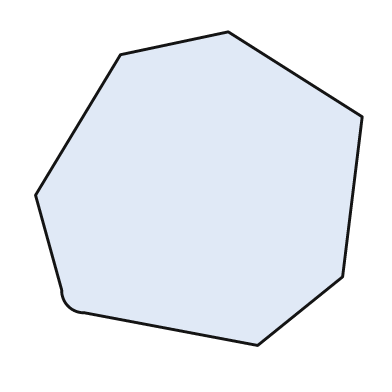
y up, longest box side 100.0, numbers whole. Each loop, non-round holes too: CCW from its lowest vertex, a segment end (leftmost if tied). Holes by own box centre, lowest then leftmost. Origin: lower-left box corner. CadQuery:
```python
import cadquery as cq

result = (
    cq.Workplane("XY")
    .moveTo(68.0, 0.0)
    .lineTo(94.0, 21.0)
    .lineTo(100.0, 70.0)
    .lineTo(59.0, 96.0)
    .lineTo(26.0, 89.0)
    .lineTo(0.0, 46.0)
    .lineTo(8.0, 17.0)
    .threePointArc((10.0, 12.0), (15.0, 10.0))
    .close()
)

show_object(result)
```